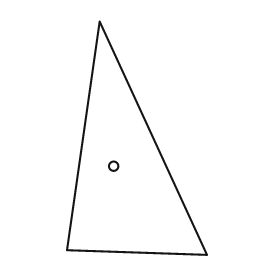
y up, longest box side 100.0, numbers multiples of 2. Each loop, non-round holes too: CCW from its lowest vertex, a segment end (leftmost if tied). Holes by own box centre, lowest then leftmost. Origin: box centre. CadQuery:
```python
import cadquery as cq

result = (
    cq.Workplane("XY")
    .moveTo(30.0, -50.0)
    .lineTo(-16.0, 50.0)
    .lineTo(-30.0, -48.0)
    .close()
    .moveTo(-10.0, -12.0)
    .circle(2.0)
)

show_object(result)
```